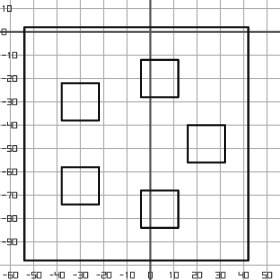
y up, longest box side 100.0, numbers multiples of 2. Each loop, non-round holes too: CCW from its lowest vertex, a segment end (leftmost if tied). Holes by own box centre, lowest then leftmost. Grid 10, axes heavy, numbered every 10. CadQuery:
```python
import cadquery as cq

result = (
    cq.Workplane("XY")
    .moveTo(-54.0, -98.0)
    .lineTo(42.0, -98.0)
    .lineTo(42.0, 2.0)
    .lineTo(-54.0, 2.0)
    .close()
    .moveTo(-4.0, -84.0)
    .lineTo(12.0, -84.0)
    .lineTo(12.0, -68.0)
    .lineTo(-4.0, -68.0)
    .close()
    .moveTo(-38.0, -74.0)
    .lineTo(-22.0, -74.0)
    .lineTo(-22.0, -58.0)
    .lineTo(-38.0, -58.0)
    .close()
    .moveTo(16.0, -56.0)
    .lineTo(32.0, -56.0)
    .lineTo(32.0, -40.0)
    .lineTo(16.0, -40.0)
    .close()
    .moveTo(-38.0, -38.0)
    .lineTo(-22.0, -38.0)
    .lineTo(-22.0, -22.0)
    .lineTo(-38.0, -22.0)
    .close()
    .moveTo(-4.0, -28.0)
    .lineTo(12.0, -28.0)
    .lineTo(12.0, -12.0)
    .lineTo(-4.0, -12.0)
    .close()
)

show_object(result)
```